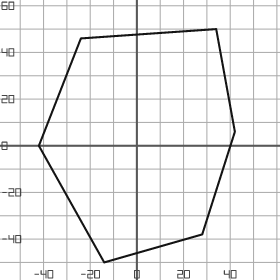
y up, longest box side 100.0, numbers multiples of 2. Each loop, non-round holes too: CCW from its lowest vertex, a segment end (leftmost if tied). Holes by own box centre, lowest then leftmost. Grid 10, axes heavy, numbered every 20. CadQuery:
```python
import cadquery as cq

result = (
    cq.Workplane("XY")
    .moveTo(-14.0, -50.0)
    .lineTo(28.0, -38.0)
    .lineTo(42.0, 6.0)
    .lineTo(34.0, 50.0)
    .lineTo(-24.0, 46.0)
    .lineTo(-42.0, 0.0)
    .close()
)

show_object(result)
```